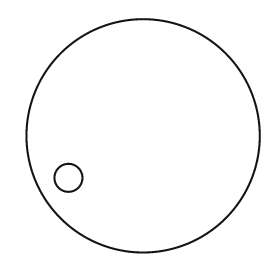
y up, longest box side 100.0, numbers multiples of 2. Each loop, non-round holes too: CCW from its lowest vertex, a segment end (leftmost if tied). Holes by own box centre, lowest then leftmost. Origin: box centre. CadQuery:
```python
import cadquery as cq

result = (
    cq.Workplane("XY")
    .moveTo(0.0, 0.0)
    .circle(50.0)
    .moveTo(-32.0, -18.0)
    .circle(6.0)
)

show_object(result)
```